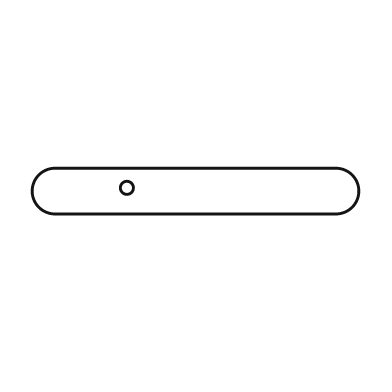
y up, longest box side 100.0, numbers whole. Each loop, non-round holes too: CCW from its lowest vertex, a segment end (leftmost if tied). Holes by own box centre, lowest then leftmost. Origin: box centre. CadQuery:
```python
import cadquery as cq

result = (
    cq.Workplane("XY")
    .moveTo(-43.0, -7.0)
    .lineTo(43.0, -7.0)
    .threePointArc((50.0, 0.0), (43.0, 7.0))
    .lineTo(-43.0, 7.0)
    .threePointArc((-50.0, 0.0), (-43.0, -7.0))
    .close()
    .moveTo(-21.0, 1.0)
    .circle(2.0)
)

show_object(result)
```